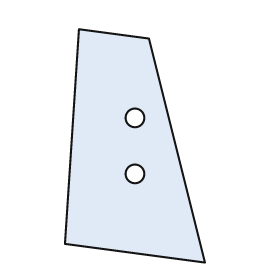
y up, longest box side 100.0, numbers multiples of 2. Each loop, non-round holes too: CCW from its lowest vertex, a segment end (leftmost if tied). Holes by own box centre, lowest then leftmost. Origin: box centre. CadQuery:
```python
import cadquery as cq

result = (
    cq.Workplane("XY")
    .moveTo(30.0, -50.0)
    .lineTo(6.0, 46.0)
    .lineTo(-24.0, 50.0)
    .lineTo(-30.0, -42.0)
    .close()
    .moveTo(0.0, -12.0)
    .circle(4.0)
    .moveTo(0.0, 12.0)
    .circle(4.0)
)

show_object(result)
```